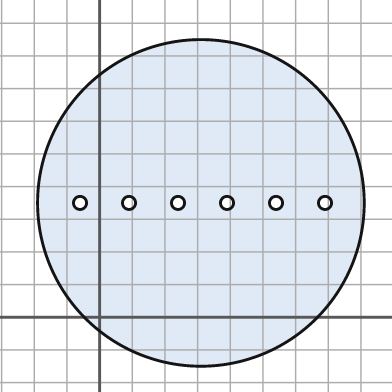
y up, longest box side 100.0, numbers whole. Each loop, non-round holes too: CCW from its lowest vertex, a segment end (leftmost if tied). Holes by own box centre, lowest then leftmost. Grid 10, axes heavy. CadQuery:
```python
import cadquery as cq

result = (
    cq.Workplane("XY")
    .moveTo(31.0, 35.0)
    .circle(50.0)
    .moveTo(-6.0, 35.0)
    .circle(2.0)
    .moveTo(9.0, 35.0)
    .circle(2.0)
    .moveTo(24.0, 35.0)
    .circle(2.0)
    .moveTo(39.0, 35.0)
    .circle(2.0)
    .moveTo(54.0, 35.0)
    .circle(2.0)
    .moveTo(69.0, 35.0)
    .circle(2.0)
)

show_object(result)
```